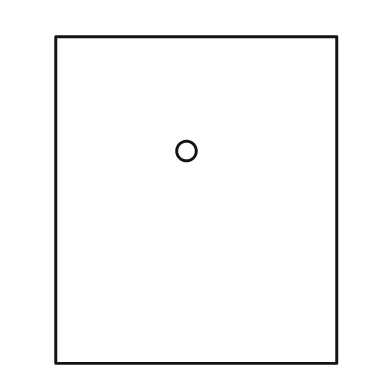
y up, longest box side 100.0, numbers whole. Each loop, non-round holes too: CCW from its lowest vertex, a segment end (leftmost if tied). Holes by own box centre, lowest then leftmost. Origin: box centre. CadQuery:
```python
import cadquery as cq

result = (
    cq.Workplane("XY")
    .moveTo(-43.0, -50.0)
    .lineTo(43.0, -50.0)
    .lineTo(43.0, 50.0)
    .lineTo(-43.0, 50.0)
    .close()
    .moveTo(-3.0, 15.0)
    .circle(3.0)
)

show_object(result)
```